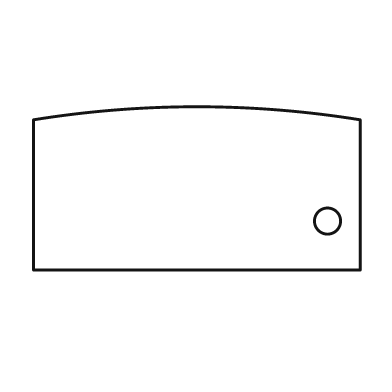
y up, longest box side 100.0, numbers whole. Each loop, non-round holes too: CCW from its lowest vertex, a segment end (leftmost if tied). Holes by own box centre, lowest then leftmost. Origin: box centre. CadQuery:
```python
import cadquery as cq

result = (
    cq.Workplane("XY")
    .moveTo(-50.0, -25.0)
    .lineTo(50.0, -25.0)
    .lineTo(50.0, 21.0)
    .threePointArc((0.0, 25.0), (-50.0, 21.0))
    .close()
    .moveTo(40.0, -10.0)
    .circle(4.0)
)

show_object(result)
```